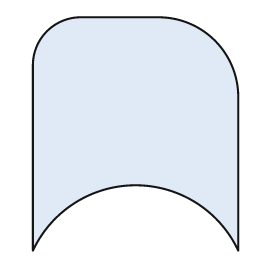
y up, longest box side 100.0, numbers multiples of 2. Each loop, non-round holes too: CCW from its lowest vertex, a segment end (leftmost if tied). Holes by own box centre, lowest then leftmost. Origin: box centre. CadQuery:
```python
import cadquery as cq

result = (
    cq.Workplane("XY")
    .moveTo(-44.0, -50.0)
    .threePointArc((0.0, -22.0), (44.0, -50.0))
    .lineTo(44.0, 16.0)
    .threePointArc((34.0, 40.0), (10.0, 50.0))
    .lineTo(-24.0, 50.0)
    .threePointArc((-38.0, 44.0), (-44.0, 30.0))
    .close()
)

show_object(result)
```